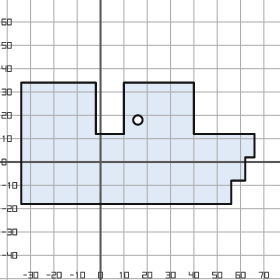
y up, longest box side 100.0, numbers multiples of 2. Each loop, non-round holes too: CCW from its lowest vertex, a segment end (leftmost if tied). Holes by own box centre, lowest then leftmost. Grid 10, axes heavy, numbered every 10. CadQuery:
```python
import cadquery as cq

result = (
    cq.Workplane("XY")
    .moveTo(-34.0, -18.0)
    .lineTo(56.0, -18.0)
    .lineTo(56.0, -8.0)
    .lineTo(62.0, -8.0)
    .lineTo(62.0, 2.0)
    .lineTo(66.0, 2.0)
    .lineTo(66.0, 12.0)
    .lineTo(40.0, 12.0)
    .lineTo(40.0, 34.0)
    .lineTo(10.0, 34.0)
    .lineTo(10.0, 12.0)
    .lineTo(-2.0, 12.0)
    .lineTo(-2.0, 34.0)
    .lineTo(-34.0, 34.0)
    .close()
    .moveTo(16.0, 18.0)
    .circle(2.0)
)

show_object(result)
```